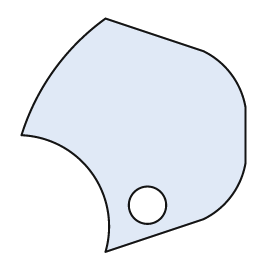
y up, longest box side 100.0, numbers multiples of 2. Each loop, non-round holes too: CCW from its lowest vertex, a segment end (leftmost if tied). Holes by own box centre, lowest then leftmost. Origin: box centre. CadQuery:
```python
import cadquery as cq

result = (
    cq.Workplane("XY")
    .moveTo(-12.0, -50.0)
    .lineTo(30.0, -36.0)
    .threePointArc((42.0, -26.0), (48.0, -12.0))
    .lineTo(48.0, 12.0)
    .threePointArc((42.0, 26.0), (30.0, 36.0))
    .lineTo(-12.0, 50.0)
    .threePointArc((-34.0, 28.0), (-48.0, 0.0))
    .threePointArc((-18.0, -16.0), (-12.0, -50.0))
    .close()
    .moveTo(6.0, -30.0)
    .circle(8.0)
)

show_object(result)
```